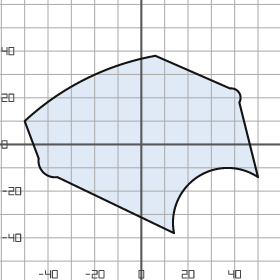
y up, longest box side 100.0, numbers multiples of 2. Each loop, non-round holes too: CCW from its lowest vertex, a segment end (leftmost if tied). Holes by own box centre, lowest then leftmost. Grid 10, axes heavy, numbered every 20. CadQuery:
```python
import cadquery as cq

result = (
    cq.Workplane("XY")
    .moveTo(14.0, -38.0)
    .threePointArc((24.0, -14.0), (50.0, -14.0))
    .lineTo(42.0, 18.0)
    .threePointArc((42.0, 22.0), (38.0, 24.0))
    .lineTo(6.0, 38.0)
    .threePointArc((-24.0, 28.0), (-50.0, 10.0))
    .lineTo(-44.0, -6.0)
    .threePointArc((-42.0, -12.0), (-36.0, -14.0))
    .close()
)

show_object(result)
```